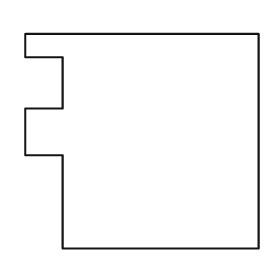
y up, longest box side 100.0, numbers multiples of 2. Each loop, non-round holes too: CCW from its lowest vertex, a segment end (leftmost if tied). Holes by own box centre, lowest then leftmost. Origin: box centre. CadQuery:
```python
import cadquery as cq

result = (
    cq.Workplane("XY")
    .moveTo(-34.0, -46.0)
    .lineTo(50.0, -46.0)
    .lineTo(50.0, 46.0)
    .lineTo(-50.0, 46.0)
    .lineTo(-50.0, 36.0)
    .lineTo(-34.0, 36.0)
    .lineTo(-34.0, 14.0)
    .lineTo(-50.0, 14.0)
    .lineTo(-50.0, -6.0)
    .lineTo(-34.0, -6.0)
    .close()
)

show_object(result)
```